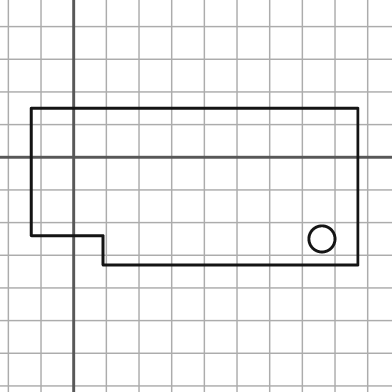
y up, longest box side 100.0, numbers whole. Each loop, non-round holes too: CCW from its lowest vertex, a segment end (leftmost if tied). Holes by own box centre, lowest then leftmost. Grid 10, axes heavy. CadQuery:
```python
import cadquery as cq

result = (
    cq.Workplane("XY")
    .moveTo(9.0, -33.0)
    .lineTo(87.0, -33.0)
    .lineTo(87.0, 15.0)
    .lineTo(-13.0, 15.0)
    .lineTo(-13.0, -24.0)
    .lineTo(9.0, -24.0)
    .close()
    .moveTo(76.0, -25.0)
    .circle(4.0)
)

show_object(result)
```